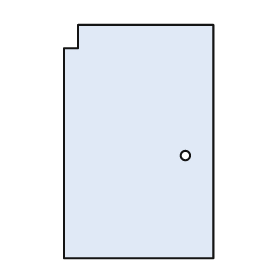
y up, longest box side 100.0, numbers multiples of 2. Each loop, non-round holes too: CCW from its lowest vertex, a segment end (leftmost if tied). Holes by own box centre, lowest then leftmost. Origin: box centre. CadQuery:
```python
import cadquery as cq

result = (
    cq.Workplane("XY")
    .moveTo(-32.0, -50.0)
    .lineTo(32.0, -50.0)
    .lineTo(32.0, 50.0)
    .lineTo(-26.0, 50.0)
    .lineTo(-26.0, 40.0)
    .lineTo(-32.0, 40.0)
    .close()
    .moveTo(20.0, -6.0)
    .circle(2.0)
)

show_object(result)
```